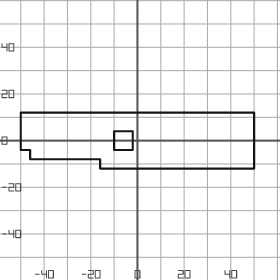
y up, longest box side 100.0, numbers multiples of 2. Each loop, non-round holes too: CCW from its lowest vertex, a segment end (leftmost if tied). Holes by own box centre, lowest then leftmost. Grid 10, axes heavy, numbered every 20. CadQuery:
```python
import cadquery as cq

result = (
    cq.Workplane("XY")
    .moveTo(-16.0, -12.0)
    .lineTo(50.0, -12.0)
    .lineTo(50.0, 12.0)
    .lineTo(-50.0, 12.0)
    .lineTo(-50.0, -4.0)
    .lineTo(-46.0, -4.0)
    .lineTo(-46.0, -8.0)
    .lineTo(-16.0, -8.0)
    .close()
    .moveTo(-10.0, -4.0)
    .lineTo(-2.0, -4.0)
    .lineTo(-2.0, 4.0)
    .lineTo(-10.0, 4.0)
    .close()
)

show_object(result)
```